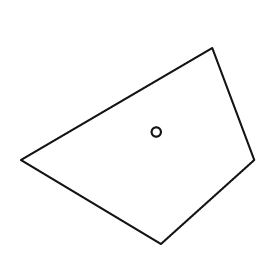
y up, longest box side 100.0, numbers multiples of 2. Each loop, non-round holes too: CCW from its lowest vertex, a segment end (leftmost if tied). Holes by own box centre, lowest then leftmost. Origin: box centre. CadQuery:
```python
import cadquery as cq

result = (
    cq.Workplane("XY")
    .moveTo(10.0, -42.0)
    .lineTo(50.0, -6.0)
    .lineTo(32.0, 42.0)
    .lineTo(-50.0, -6.0)
    .close()
    .moveTo(8.0, 6.0)
    .circle(2.0)
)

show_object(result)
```